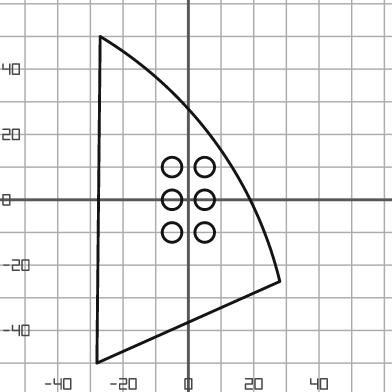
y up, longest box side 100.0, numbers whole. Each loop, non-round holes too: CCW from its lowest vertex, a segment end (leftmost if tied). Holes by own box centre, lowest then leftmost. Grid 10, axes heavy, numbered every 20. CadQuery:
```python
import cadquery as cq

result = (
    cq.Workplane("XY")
    .moveTo(-28.0, -50.0)
    .lineTo(28.0, -25.0)
    .threePointArc((8.0, 18.0), (-27.0, 50.0))
    .close()
    .moveTo(-5.0, -10.0)
    .circle(3.0)
    .moveTo(5.0, -10.0)
    .circle(3.0)
    .moveTo(-5.0, 0.0)
    .circle(3.0)
    .moveTo(5.0, 0.0)
    .circle(3.0)
    .moveTo(-5.0, 10.0)
    .circle(3.0)
    .moveTo(5.0, 10.0)
    .circle(3.0)
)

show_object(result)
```